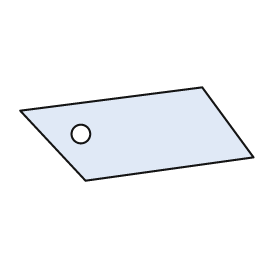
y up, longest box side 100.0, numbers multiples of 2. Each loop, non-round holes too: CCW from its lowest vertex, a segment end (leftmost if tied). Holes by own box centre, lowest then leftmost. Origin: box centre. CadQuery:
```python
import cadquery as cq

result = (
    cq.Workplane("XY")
    .moveTo(-22.0, -20.0)
    .lineTo(50.0, -10.0)
    .lineTo(28.0, 20.0)
    .lineTo(-50.0, 10.0)
    .close()
    .moveTo(-24.0, 0.0)
    .circle(4.0)
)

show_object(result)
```